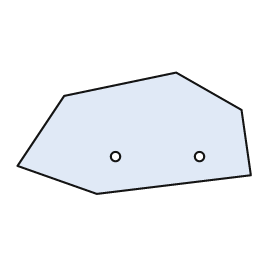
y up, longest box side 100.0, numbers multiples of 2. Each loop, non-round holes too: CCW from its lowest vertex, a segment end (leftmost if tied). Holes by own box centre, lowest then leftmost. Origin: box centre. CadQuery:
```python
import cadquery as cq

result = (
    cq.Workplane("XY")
    .moveTo(-16.0, -26.0)
    .lineTo(50.0, -18.0)
    .lineTo(46.0, 10.0)
    .lineTo(18.0, 26.0)
    .lineTo(-30.0, 16.0)
    .lineTo(-50.0, -14.0)
    .close()
    .moveTo(-8.0, -10.0)
    .circle(2.0)
    .moveTo(28.0, -10.0)
    .circle(2.0)
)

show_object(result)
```